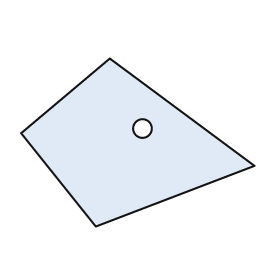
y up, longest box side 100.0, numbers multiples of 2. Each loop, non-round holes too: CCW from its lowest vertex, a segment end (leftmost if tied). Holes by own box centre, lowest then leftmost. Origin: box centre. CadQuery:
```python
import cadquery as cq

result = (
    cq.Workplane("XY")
    .moveTo(-18.0, -36.0)
    .lineTo(50.0, -10.0)
    .lineTo(-12.0, 36.0)
    .lineTo(-50.0, 4.0)
    .close()
    .moveTo(2.0, 6.0)
    .circle(4.0)
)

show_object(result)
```